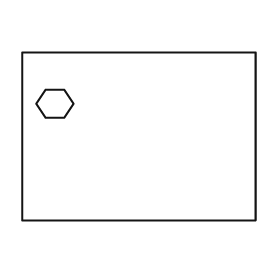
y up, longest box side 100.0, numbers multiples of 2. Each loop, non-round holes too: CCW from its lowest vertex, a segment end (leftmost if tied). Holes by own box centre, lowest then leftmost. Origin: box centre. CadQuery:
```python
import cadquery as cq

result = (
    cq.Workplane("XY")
    .moveTo(-50.0, -36.0)
    .lineTo(50.0, -36.0)
    .lineTo(50.0, 36.0)
    .lineTo(-50.0, 36.0)
    .close()
    .moveTo(-40.0, 8.0)
    .lineTo(-32.0, 8.0)
    .lineTo(-28.0, 14.0)
    .lineTo(-32.0, 20.0)
    .lineTo(-40.0, 20.0)
    .lineTo(-44.0, 14.0)
    .close()
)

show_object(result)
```